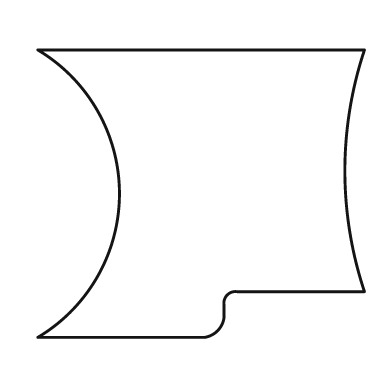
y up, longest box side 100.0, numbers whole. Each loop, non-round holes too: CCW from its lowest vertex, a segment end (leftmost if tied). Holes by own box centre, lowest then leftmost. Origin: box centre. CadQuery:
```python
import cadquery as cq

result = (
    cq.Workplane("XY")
    .moveTo(-50.0, -44.0)
    .lineTo(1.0, -44.0)
    .threePointArc((5.0, -42.0), (7.0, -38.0))
    .lineTo(7.0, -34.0)
    .threePointArc((8.0, -31.0), (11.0, -30.0))
    .lineTo(50.0, -30.0)
    .threePointArc((44.0, 7.0), (50.0, 44.0))
    .lineTo(-50.0, 44.0)
    .threePointArc((-25.0, 0.0), (-50.0, -44.0))
    .close()
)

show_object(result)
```